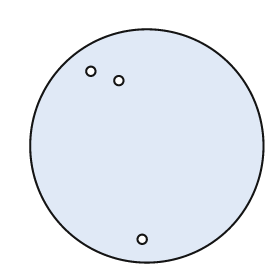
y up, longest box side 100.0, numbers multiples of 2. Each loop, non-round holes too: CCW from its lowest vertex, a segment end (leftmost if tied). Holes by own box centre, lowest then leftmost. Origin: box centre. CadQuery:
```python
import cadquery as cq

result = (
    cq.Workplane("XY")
    .moveTo(0.0, 0.0)
    .circle(50.0)
    .moveTo(-2.0, -40.0)
    .circle(2.0)
    .moveTo(-12.0, 28.0)
    .circle(2.0)
    .moveTo(-24.0, 32.0)
    .circle(2.0)
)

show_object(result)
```